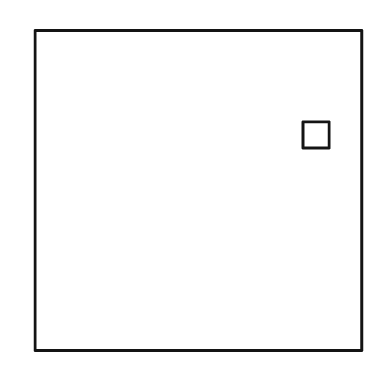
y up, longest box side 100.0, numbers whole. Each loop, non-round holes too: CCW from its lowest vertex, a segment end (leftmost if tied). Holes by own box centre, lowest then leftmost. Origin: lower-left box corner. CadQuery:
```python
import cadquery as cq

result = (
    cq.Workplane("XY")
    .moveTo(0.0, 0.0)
    .lineTo(100.0, 0.0)
    .lineTo(100.0, 98.0)
    .lineTo(0.0, 98.0)
    .close()
    .moveTo(82.0, 62.0)
    .lineTo(90.0, 62.0)
    .lineTo(90.0, 70.0)
    .lineTo(82.0, 70.0)
    .close()
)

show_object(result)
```